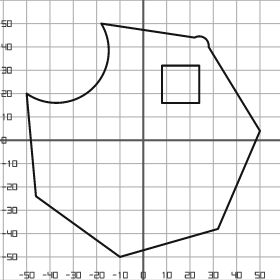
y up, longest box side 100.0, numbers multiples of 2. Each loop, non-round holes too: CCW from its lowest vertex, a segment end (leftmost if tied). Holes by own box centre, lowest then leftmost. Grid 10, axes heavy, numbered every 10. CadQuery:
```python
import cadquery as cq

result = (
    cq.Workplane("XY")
    .moveTo(-10.0, -50.0)
    .lineTo(32.0, -38.0)
    .lineTo(50.0, 4.0)
    .lineTo(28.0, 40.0)
    .threePointArc((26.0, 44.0), (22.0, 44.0))
    .lineTo(-18.0, 50.0)
    .threePointArc((-22.0, 22.0), (-50.0, 20.0))
    .lineTo(-46.0, -24.0)
    .close()
    .moveTo(8.0, 16.0)
    .lineTo(24.0, 16.0)
    .lineTo(24.0, 32.0)
    .lineTo(8.0, 32.0)
    .close()
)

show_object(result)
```